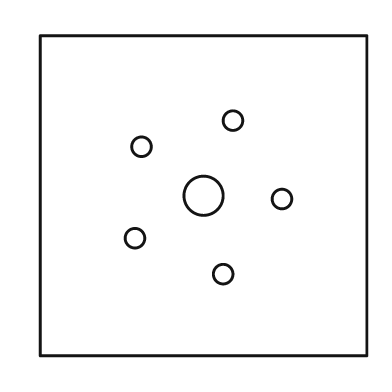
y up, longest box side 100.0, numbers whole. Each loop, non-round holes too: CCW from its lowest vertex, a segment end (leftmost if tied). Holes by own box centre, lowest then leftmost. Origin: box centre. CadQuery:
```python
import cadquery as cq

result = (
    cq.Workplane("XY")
    .moveTo(-50.0, -49.0)
    .lineTo(50.0, -49.0)
    .lineTo(50.0, 49.0)
    .lineTo(-50.0, 49.0)
    .close()
    .moveTo(6.0, -24.0)
    .circle(3.0)
    .moveTo(-21.0, -13.0)
    .circle(3.0)
    .moveTo(24.0, -1.0)
    .circle(3.0)
    .moveTo(0.0, 0.0)
    .circle(6.0)
    .moveTo(-19.0, 15.0)
    .circle(3.0)
    .moveTo(9.0, 23.0)
    .circle(3.0)
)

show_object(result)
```